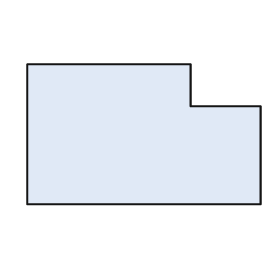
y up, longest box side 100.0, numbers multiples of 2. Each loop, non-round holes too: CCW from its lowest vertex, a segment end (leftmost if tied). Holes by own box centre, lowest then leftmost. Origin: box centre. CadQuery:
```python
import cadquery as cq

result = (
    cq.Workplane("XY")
    .moveTo(-50.0, -30.0)
    .lineTo(50.0, -30.0)
    .lineTo(50.0, 12.0)
    .lineTo(20.0, 12.0)
    .lineTo(20.0, 30.0)
    .lineTo(-50.0, 30.0)
    .close()
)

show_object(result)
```